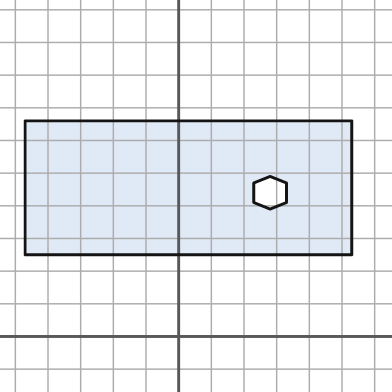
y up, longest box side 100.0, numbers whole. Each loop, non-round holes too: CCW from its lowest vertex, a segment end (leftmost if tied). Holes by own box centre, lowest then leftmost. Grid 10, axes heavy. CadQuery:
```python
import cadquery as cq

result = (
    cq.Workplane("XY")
    .moveTo(-47.0, 25.0)
    .lineTo(53.0, 25.0)
    .lineTo(53.0, 66.0)
    .lineTo(-47.0, 66.0)
    .close()
    .moveTo(28.0, 39.0)
    .lineTo(33.0, 41.0)
    .lineTo(33.0, 47.0)
    .lineTo(28.0, 49.0)
    .lineTo(23.0, 47.0)
    .lineTo(23.0, 41.0)
    .close()
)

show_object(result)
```